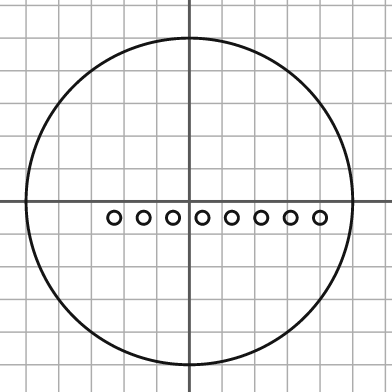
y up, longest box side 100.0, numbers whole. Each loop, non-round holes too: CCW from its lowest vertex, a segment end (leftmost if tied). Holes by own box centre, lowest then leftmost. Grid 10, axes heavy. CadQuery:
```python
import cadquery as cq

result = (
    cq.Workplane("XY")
    .moveTo(0.0, 0.0)
    .circle(50.0)
    .moveTo(-23.0, -5.0)
    .circle(2.0)
    .moveTo(-14.0, -5.0)
    .circle(2.0)
    .moveTo(-5.0, -5.0)
    .circle(2.0)
    .moveTo(4.0, -5.0)
    .circle(2.0)
    .moveTo(13.0, -5.0)
    .circle(2.0)
    .moveTo(22.0, -5.0)
    .circle(2.0)
    .moveTo(31.0, -5.0)
    .circle(2.0)
    .moveTo(40.0, -5.0)
    .circle(2.0)
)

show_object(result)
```